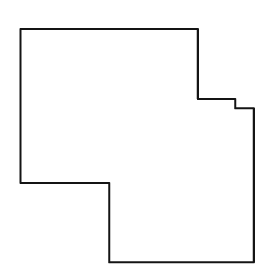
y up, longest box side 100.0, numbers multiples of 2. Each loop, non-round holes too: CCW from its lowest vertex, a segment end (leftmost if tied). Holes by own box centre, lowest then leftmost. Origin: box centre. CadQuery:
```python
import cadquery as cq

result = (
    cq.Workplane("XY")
    .moveTo(-12.0, -50.0)
    .lineTo(50.0, -50.0)
    .lineTo(50.0, 16.0)
    .lineTo(42.0, 16.0)
    .lineTo(42.0, 20.0)
    .lineTo(26.0, 20.0)
    .lineTo(26.0, 50.0)
    .lineTo(-50.0, 50.0)
    .lineTo(-50.0, -16.0)
    .lineTo(-12.0, -16.0)
    .close()
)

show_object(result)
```